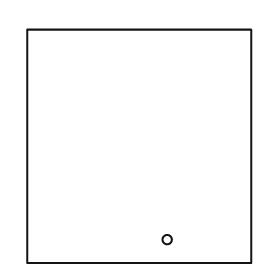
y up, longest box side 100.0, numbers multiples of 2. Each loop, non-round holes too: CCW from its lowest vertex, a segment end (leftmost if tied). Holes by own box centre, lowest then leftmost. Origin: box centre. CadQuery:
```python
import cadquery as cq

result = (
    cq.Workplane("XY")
    .moveTo(-48.0, -50.0)
    .lineTo(48.0, -50.0)
    .lineTo(48.0, 50.0)
    .lineTo(-48.0, 50.0)
    .close()
    .moveTo(12.0, -40.0)
    .circle(2.0)
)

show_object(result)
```